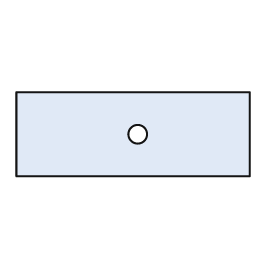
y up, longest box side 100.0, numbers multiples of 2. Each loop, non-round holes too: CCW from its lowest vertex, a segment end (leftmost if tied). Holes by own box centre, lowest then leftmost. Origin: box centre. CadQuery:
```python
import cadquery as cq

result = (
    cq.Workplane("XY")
    .moveTo(-50.0, -18.0)
    .lineTo(50.0, -18.0)
    .lineTo(50.0, 18.0)
    .lineTo(-50.0, 18.0)
    .close()
    .moveTo(2.0, 0.0)
    .circle(4.0)
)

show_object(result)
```